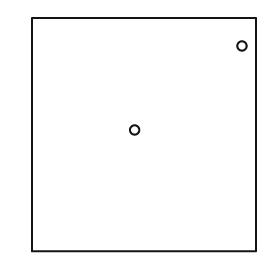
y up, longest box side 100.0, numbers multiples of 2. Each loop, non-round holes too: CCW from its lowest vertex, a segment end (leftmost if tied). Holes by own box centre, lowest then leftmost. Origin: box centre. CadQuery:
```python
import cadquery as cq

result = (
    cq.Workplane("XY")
    .moveTo(-48.0, -50.0)
    .lineTo(48.0, -50.0)
    .lineTo(48.0, 50.0)
    .lineTo(-48.0, 50.0)
    .close()
    .moveTo(-4.0, 2.0)
    .circle(2.0)
    .moveTo(42.0, 38.0)
    .circle(2.0)
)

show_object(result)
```